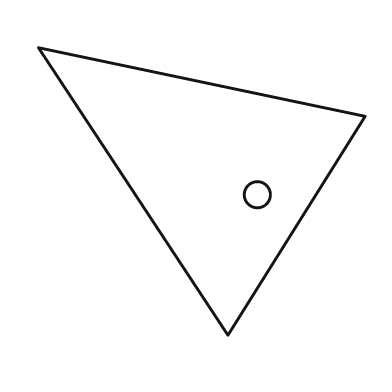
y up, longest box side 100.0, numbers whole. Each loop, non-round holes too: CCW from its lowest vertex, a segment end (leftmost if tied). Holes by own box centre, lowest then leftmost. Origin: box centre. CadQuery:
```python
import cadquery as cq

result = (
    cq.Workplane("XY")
    .moveTo(8.0, -44.0)
    .lineTo(50.0, 23.0)
    .lineTo(-50.0, 44.0)
    .close()
    .moveTo(17.0, -1.0)
    .circle(4.0)
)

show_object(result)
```